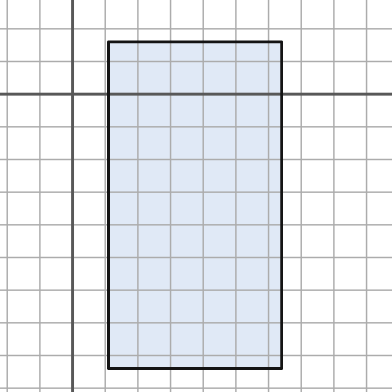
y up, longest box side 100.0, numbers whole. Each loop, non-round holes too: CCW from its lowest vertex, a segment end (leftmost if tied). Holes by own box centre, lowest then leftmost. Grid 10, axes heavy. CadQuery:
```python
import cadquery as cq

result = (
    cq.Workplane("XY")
    .moveTo(11.0, -84.0)
    .lineTo(64.0, -84.0)
    .lineTo(64.0, 16.0)
    .lineTo(11.0, 16.0)
    .close()
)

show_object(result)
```